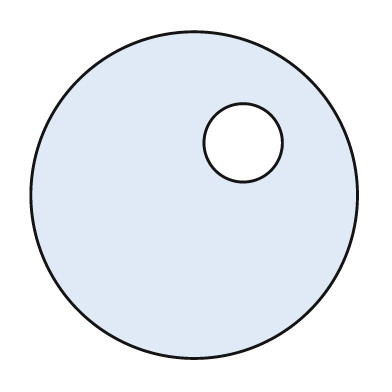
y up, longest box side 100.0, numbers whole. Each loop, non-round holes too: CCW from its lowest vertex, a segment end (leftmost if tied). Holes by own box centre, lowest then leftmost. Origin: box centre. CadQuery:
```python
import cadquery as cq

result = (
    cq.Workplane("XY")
    .moveTo(0.0, 0.0)
    .circle(50.0)
    .moveTo(15.0, 16.0)
    .circle(12.0)
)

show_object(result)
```